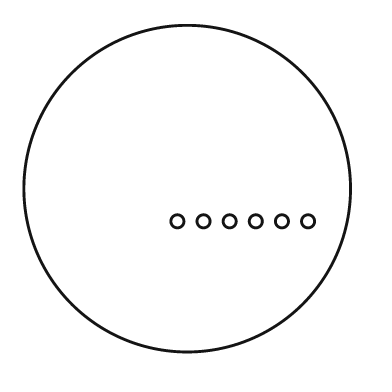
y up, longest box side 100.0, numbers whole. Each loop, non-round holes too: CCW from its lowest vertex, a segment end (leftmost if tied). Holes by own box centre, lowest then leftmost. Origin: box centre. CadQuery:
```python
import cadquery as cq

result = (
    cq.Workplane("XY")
    .moveTo(0.0, 0.0)
    .circle(50.0)
    .moveTo(-3.0, -10.0)
    .circle(2.0)
    .moveTo(5.0, -10.0)
    .circle(2.0)
    .moveTo(13.0, -10.0)
    .circle(2.0)
    .moveTo(21.0, -10.0)
    .circle(2.0)
    .moveTo(29.0, -10.0)
    .circle(2.0)
    .moveTo(37.0, -10.0)
    .circle(2.0)
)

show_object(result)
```